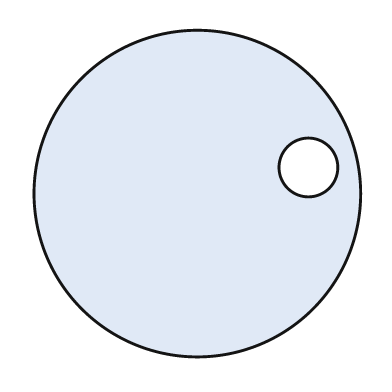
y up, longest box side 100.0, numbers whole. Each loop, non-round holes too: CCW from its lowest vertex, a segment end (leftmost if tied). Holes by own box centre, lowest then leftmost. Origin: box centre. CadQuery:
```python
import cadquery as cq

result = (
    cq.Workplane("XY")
    .moveTo(0.0, 0.0)
    .circle(50.0)
    .moveTo(34.0, 8.0)
    .circle(9.0)
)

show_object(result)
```